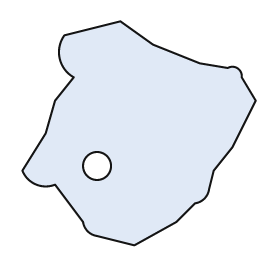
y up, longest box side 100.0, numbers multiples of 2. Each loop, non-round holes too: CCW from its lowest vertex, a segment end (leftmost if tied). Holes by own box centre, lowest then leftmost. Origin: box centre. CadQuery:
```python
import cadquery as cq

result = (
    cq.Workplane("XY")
    .moveTo(-2.0, -48.0)
    .lineTo(16.0, -38.0)
    .lineTo(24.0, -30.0)
    .threePointArc((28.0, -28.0), (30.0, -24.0))
    .lineTo(32.0, -16.0)
    .lineTo(40.0, -6.0)
    .lineTo(50.0, 14.0)
    .lineTo(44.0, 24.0)
    .threePointArc((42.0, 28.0), (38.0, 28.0))
    .lineTo(26.0, 30.0)
    .lineTo(6.0, 38.0)
    .lineTo(-8.0, 48.0)
    .lineTo(-32.0, 42.0)
    .threePointArc((-34.0, 32.0), (-28.0, 24.0))
    .lineTo(-36.0, 14.0)
    .lineTo(-40.0, 0.0)
    .lineTo(-50.0, -16.0)
    .threePointArc((-44.0, -22.0), (-36.0, -22.0))
    .lineTo(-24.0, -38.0)
    .threePointArc((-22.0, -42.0), (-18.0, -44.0))
    .close()
    .moveTo(-18.0, -14.0)
    .circle(6.0)
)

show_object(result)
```